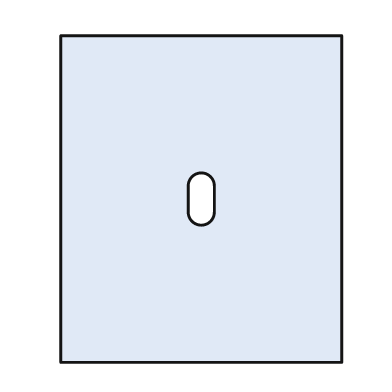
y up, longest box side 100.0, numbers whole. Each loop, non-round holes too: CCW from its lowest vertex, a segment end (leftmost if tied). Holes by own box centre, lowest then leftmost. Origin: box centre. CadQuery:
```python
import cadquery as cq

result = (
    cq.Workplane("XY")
    .moveTo(-43.0, -50.0)
    .lineTo(43.0, -50.0)
    .lineTo(43.0, 50.0)
    .lineTo(-43.0, 50.0)
    .close()
    .moveTo(-4.0, -4.0)
    .threePointArc((0.0, -8.0), (4.0, -4.0))
    .lineTo(4.0, 4.0)
    .threePointArc((0.0, 8.0), (-4.0, 4.0))
    .close()
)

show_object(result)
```